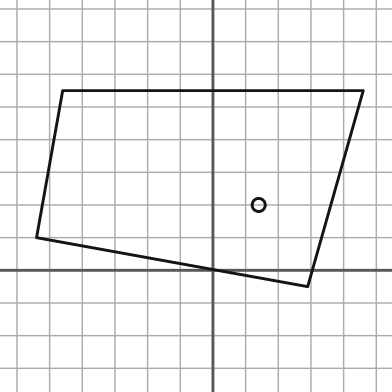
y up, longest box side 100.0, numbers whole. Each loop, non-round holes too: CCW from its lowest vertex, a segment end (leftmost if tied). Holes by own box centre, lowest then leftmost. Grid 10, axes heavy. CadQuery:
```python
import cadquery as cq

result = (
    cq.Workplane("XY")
    .moveTo(29.0, -5.0)
    .lineTo(46.0, 55.0)
    .lineTo(-46.0, 55.0)
    .lineTo(-54.0, 10.0)
    .close()
    .moveTo(14.0, 20.0)
    .circle(2.0)
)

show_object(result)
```